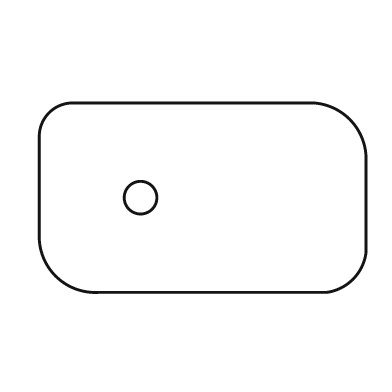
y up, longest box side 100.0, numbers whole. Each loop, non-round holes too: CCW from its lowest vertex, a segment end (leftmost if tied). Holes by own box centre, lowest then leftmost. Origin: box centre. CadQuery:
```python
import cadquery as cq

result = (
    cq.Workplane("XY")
    .moveTo(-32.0, -29.0)
    .lineTo(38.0, -29.0)
    .threePointArc((46.0, -25.0), (50.0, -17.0))
    .lineTo(50.0, 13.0)
    .threePointArc((45.0, 24.0), (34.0, 29.0))
    .lineTo(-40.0, 29.0)
    .threePointArc((-47.0, 26.0), (-50.0, 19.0))
    .lineTo(-50.0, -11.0)
    .threePointArc((-45.0, -24.0), (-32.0, -29.0))
    .close()
    .moveTo(-19.0, 0.0)
    .circle(5.0)
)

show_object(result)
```